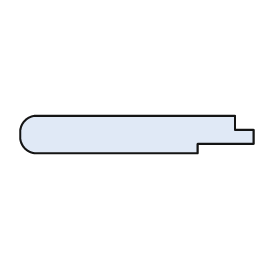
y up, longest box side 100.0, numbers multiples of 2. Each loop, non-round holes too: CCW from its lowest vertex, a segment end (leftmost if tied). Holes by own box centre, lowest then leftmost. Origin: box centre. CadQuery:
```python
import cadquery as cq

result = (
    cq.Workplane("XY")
    .moveTo(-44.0, -8.0)
    .lineTo(26.0, -8.0)
    .lineTo(26.0, -4.0)
    .lineTo(50.0, -4.0)
    .lineTo(50.0, 2.0)
    .lineTo(42.0, 2.0)
    .lineTo(42.0, 8.0)
    .lineTo(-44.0, 8.0)
    .threePointArc((-48.0, 6.0), (-50.0, 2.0))
    .lineTo(-50.0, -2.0)
    .threePointArc((-48.0, -6.0), (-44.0, -8.0))
    .close()
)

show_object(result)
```